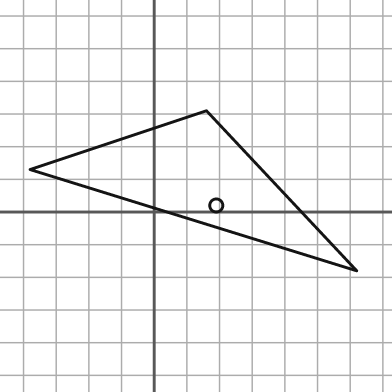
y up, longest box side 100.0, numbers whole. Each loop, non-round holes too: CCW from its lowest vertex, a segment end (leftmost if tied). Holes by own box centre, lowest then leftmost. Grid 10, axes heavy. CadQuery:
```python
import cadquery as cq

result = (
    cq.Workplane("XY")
    .moveTo(62.0, -18.0)
    .lineTo(16.0, 31.0)
    .lineTo(-38.0, 13.0)
    .close()
    .moveTo(19.0, 2.0)
    .circle(2.0)
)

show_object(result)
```